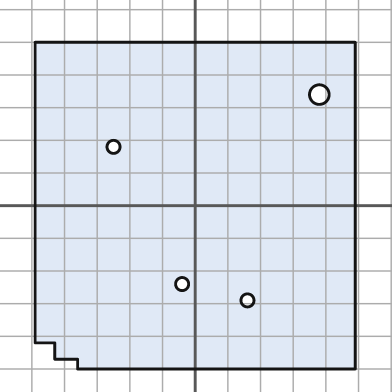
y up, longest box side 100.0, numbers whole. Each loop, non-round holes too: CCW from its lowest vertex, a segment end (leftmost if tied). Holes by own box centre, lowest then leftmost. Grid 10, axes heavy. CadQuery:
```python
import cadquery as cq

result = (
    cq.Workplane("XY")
    .moveTo(-36.0, -50.0)
    .lineTo(49.0, -50.0)
    .lineTo(49.0, 50.0)
    .lineTo(-49.0, 50.0)
    .lineTo(-49.0, -42.0)
    .lineTo(-43.0, -42.0)
    .lineTo(-43.0, -47.0)
    .lineTo(-36.0, -47.0)
    .close()
    .moveTo(16.0, -29.0)
    .circle(2.0)
    .moveTo(-4.0, -24.0)
    .circle(2.0)
    .moveTo(-25.0, 18.0)
    .circle(2.0)
    .moveTo(38.0, 34.0)
    .circle(3.0)
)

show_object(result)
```